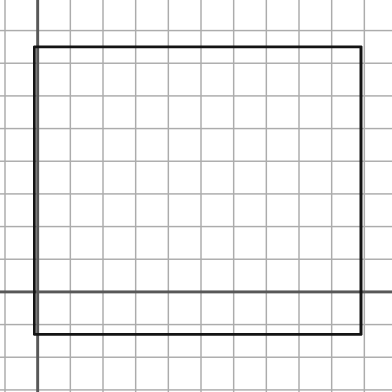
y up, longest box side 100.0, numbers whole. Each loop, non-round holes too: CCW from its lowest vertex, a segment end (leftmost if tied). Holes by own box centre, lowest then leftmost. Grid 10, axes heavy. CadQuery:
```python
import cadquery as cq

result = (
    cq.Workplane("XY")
    .moveTo(-1.0, -13.0)
    .lineTo(99.0, -13.0)
    .lineTo(99.0, 75.0)
    .lineTo(-1.0, 75.0)
    .close()
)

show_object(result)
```